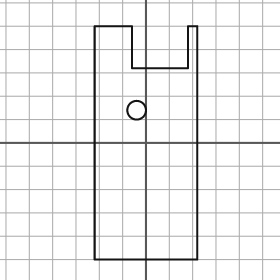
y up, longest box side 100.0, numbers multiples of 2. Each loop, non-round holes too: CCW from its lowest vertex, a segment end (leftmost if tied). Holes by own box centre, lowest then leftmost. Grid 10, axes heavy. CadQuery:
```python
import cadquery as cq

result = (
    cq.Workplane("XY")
    .moveTo(-22.0, -50.0)
    .lineTo(22.0, -50.0)
    .lineTo(22.0, 50.0)
    .lineTo(18.0, 50.0)
    .lineTo(18.0, 32.0)
    .lineTo(-6.0, 32.0)
    .lineTo(-6.0, 50.0)
    .lineTo(-22.0, 50.0)
    .close()
    .moveTo(-4.0, 14.0)
    .circle(4.0)
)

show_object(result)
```